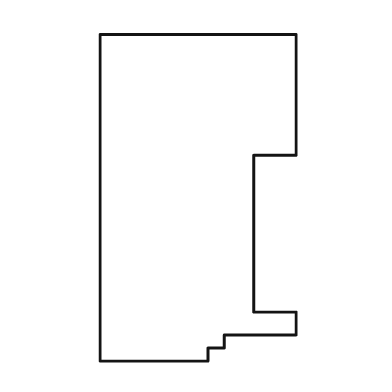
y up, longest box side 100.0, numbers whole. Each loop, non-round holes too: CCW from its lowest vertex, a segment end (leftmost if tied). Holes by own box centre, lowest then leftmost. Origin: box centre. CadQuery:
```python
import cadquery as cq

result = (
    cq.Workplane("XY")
    .moveTo(-30.0, -50.0)
    .lineTo(3.0, -50.0)
    .lineTo(3.0, -46.0)
    .lineTo(8.0, -46.0)
    .lineTo(8.0, -42.0)
    .lineTo(30.0, -42.0)
    .lineTo(30.0, -35.0)
    .lineTo(17.0, -35.0)
    .lineTo(17.0, 13.0)
    .lineTo(30.0, 13.0)
    .lineTo(30.0, 50.0)
    .lineTo(-30.0, 50.0)
    .close()
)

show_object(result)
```